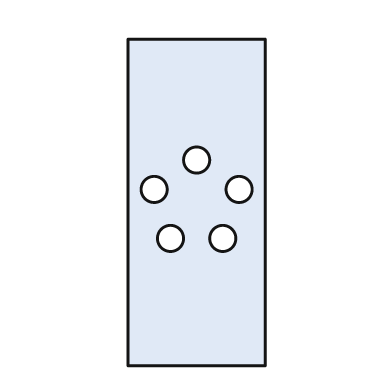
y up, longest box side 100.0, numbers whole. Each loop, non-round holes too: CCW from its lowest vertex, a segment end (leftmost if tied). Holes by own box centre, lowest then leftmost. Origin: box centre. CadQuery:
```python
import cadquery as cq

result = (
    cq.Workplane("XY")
    .moveTo(-21.0, -50.0)
    .lineTo(21.0, -50.0)
    .lineTo(21.0, 50.0)
    .lineTo(-21.0, 50.0)
    .close()
    .moveTo(-8.0, -11.0)
    .circle(4.0)
    .moveTo(8.0, -11.0)
    .circle(4.0)
    .moveTo(-13.0, 4.0)
    .circle(4.0)
    .moveTo(13.0, 4.0)
    .circle(4.0)
    .moveTo(0.0, 13.0)
    .circle(4.0)
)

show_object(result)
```